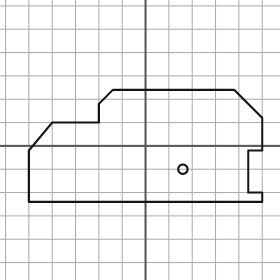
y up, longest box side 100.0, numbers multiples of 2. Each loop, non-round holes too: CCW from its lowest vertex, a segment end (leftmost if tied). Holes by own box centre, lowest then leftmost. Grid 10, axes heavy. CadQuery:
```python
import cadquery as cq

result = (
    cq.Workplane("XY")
    .moveTo(-50.0, -24.0)
    .lineTo(50.0, -24.0)
    .lineTo(50.0, -20.0)
    .lineTo(44.0, -20.0)
    .lineTo(44.0, -2.0)
    .lineTo(50.0, -2.0)
    .lineTo(50.0, 12.0)
    .lineTo(38.0, 24.0)
    .lineTo(-14.0, 24.0)
    .lineTo(-20.0, 18.0)
    .lineTo(-20.0, 10.0)
    .lineTo(-40.0, 10.0)
    .lineTo(-50.0, -2.0)
    .close()
    .moveTo(16.0, -10.0)
    .circle(2.0)
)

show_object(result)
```